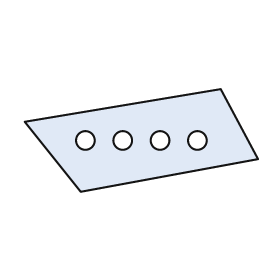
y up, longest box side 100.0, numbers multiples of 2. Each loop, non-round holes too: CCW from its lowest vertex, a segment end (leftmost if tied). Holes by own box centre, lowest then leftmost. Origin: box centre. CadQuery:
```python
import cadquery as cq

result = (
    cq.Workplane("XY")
    .moveTo(-26.0, -22.0)
    .lineTo(50.0, -8.0)
    .lineTo(34.0, 22.0)
    .lineTo(-50.0, 8.0)
    .close()
    .moveTo(-24.0, 0.0)
    .circle(4.0)
    .moveTo(-8.0, 0.0)
    .circle(4.0)
    .moveTo(8.0, 0.0)
    .circle(4.0)
    .moveTo(24.0, 0.0)
    .circle(4.0)
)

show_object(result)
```